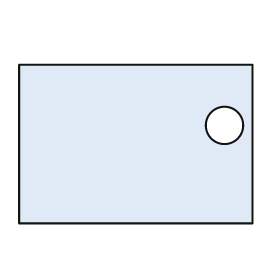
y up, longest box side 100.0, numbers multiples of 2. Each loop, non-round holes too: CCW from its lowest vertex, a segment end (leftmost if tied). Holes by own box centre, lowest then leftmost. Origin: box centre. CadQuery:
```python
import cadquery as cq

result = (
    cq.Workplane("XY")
    .moveTo(-50.0, -34.0)
    .lineTo(50.0, -34.0)
    .lineTo(50.0, 34.0)
    .lineTo(-50.0, 34.0)
    .close()
    .moveTo(38.0, 8.0)
    .circle(8.0)
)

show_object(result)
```